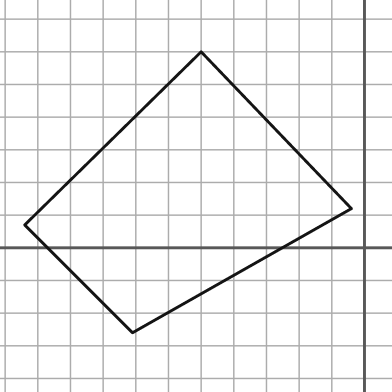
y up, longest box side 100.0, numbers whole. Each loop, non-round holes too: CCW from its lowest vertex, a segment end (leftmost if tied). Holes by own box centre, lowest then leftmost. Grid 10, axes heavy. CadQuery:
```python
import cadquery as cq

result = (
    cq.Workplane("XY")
    .moveTo(-71.0, -26.0)
    .lineTo(-4.0, 12.0)
    .lineTo(-50.0, 60.0)
    .lineTo(-104.0, 7.0)
    .close()
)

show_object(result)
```